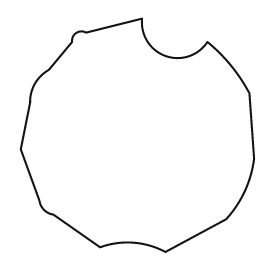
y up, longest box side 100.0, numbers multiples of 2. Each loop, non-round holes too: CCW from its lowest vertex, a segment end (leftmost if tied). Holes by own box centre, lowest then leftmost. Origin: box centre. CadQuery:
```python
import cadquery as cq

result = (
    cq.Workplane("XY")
    .moveTo(12.0, -50.0)
    .lineTo(38.0, -36.0)
    .threePointArc((46.0, -24.0), (50.0, -10.0))
    .lineTo(48.0, 18.0)
    .threePointArc((40.0, 30.0), (30.0, 40.0))
    .threePointArc((12.0, 34.0), (2.0, 50.0))
    .lineTo(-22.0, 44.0)
    .threePointArc((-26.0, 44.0), (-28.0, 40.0))
    .lineTo(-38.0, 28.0)
    .threePointArc((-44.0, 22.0), (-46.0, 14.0))
    .lineTo(-50.0, -6.0)
    .lineTo(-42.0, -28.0)
    .threePointArc((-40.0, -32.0), (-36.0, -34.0))
    .lineTo(-16.0, -48.0)
    .threePointArc((-2.0, -46.0), (12.0, -50.0))
    .close()
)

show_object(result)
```